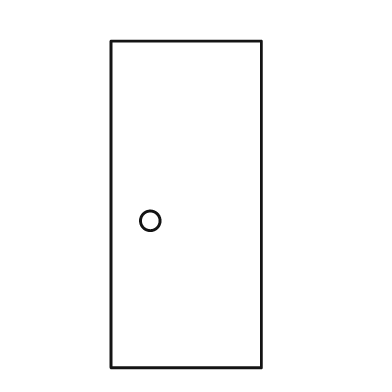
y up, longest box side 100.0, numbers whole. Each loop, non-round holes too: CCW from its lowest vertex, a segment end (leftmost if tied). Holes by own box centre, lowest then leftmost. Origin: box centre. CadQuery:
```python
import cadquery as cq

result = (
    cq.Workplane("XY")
    .moveTo(-23.0, -50.0)
    .lineTo(23.0, -50.0)
    .lineTo(23.0, 50.0)
    .lineTo(-23.0, 50.0)
    .close()
    .moveTo(-11.0, -5.0)
    .circle(3.0)
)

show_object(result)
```